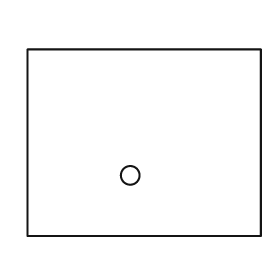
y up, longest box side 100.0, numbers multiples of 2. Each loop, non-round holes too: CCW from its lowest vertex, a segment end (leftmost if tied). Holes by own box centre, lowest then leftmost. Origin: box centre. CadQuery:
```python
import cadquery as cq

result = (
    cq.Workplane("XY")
    .moveTo(-50.0, -40.0)
    .lineTo(50.0, -40.0)
    .lineTo(50.0, 40.0)
    .lineTo(-50.0, 40.0)
    .close()
    .moveTo(-6.0, -14.0)
    .circle(4.0)
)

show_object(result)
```